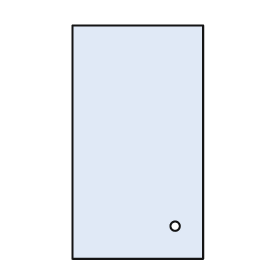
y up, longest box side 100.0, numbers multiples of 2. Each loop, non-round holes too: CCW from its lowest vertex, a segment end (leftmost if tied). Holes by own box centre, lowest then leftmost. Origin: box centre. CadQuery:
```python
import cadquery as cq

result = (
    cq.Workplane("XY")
    .moveTo(-28.0, -50.0)
    .lineTo(28.0, -50.0)
    .lineTo(28.0, 50.0)
    .lineTo(-28.0, 50.0)
    .close()
    .moveTo(16.0, -36.0)
    .circle(2.0)
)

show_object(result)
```